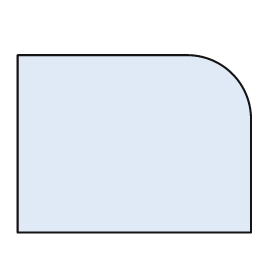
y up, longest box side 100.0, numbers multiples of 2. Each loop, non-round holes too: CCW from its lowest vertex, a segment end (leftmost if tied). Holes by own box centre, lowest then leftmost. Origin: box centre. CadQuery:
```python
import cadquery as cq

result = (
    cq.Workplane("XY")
    .moveTo(-50.0, -38.0)
    .lineTo(50.0, -38.0)
    .lineTo(50.0, 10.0)
    .threePointArc((42.0, 30.0), (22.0, 38.0))
    .lineTo(-50.0, 38.0)
    .close()
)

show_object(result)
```